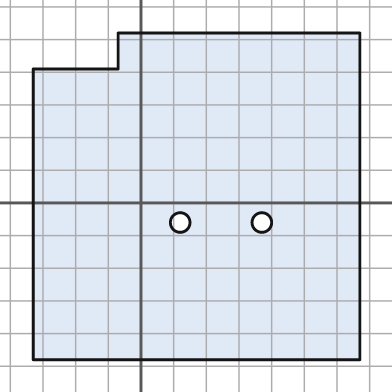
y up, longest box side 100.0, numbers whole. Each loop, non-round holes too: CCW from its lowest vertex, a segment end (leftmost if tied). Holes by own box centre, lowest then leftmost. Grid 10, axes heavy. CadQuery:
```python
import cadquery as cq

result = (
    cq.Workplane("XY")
    .moveTo(-33.0, -48.0)
    .lineTo(67.0, -48.0)
    .lineTo(67.0, 52.0)
    .lineTo(-7.0, 52.0)
    .lineTo(-7.0, 41.0)
    .lineTo(-33.0, 41.0)
    .close()
    .moveTo(12.0, -6.0)
    .circle(3.0)
    .moveTo(37.0, -6.0)
    .circle(3.0)
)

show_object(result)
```